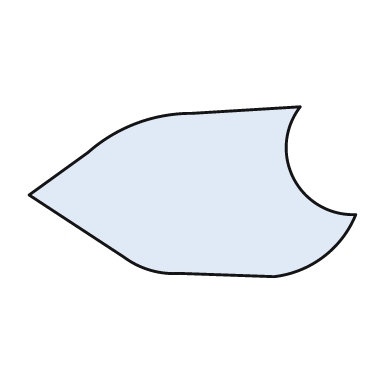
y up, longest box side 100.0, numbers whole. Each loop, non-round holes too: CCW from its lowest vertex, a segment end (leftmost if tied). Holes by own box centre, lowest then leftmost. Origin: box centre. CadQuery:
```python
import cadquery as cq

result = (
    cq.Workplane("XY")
    .moveTo(25.0, -26.0)
    .threePointArc((40.0, -20.0), (50.0, -7.0))
    .threePointArc((31.0, 4.0), (33.0, 26.0))
    .lineTo(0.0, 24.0)
    .threePointArc((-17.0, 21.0), (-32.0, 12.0))
    .lineTo(-50.0, -1.0)
    .lineTo(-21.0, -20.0)
    .threePointArc((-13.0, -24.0), (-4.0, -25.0))
    .close()
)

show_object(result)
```